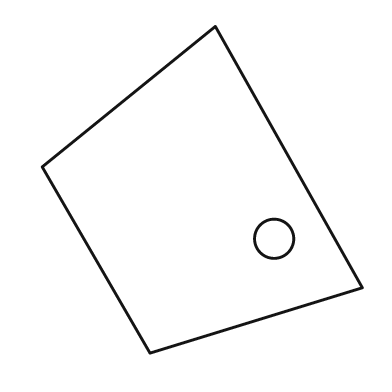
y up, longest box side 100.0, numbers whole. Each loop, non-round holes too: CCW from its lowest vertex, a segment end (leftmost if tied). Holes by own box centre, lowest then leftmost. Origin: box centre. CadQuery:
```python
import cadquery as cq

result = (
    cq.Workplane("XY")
    .moveTo(-16.0, -50.0)
    .lineTo(49.0, -30.0)
    .lineTo(4.0, 50.0)
    .lineTo(-49.0, 7.0)
    .close()
    .moveTo(22.0, -15.0)
    .circle(6.0)
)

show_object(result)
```